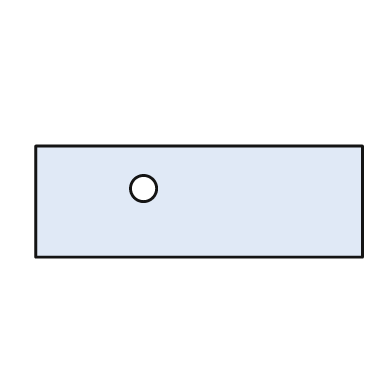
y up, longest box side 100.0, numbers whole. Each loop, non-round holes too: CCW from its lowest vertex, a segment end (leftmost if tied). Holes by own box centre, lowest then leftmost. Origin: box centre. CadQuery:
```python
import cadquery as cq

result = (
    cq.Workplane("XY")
    .moveTo(-50.0, -17.0)
    .lineTo(50.0, -17.0)
    .lineTo(50.0, 17.0)
    .lineTo(-50.0, 17.0)
    .close()
    .moveTo(-17.0, 4.0)
    .circle(4.0)
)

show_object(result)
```